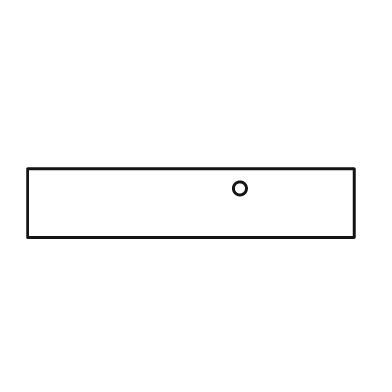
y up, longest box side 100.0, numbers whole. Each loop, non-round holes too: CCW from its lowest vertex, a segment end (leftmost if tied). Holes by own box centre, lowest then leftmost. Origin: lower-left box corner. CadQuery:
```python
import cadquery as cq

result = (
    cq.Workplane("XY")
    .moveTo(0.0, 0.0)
    .lineTo(100.0, 0.0)
    .lineTo(100.0, 21.0)
    .lineTo(0.0, 21.0)
    .close()
    .moveTo(65.0, 15.0)
    .circle(2.0)
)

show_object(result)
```